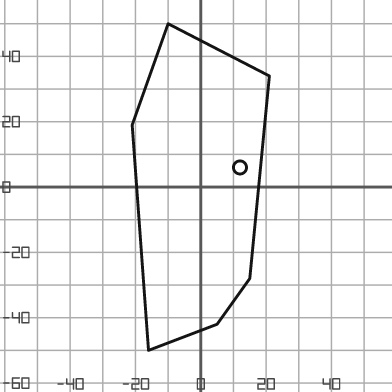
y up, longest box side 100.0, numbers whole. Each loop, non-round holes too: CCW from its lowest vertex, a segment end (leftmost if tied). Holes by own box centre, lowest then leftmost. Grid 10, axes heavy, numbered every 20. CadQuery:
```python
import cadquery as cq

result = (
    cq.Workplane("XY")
    .moveTo(-16.0, -50.0)
    .lineTo(5.0, -42.0)
    .lineTo(15.0, -28.0)
    .lineTo(21.0, 34.0)
    .lineTo(-10.0, 50.0)
    .lineTo(-21.0, 19.0)
    .close()
    .moveTo(12.0, 6.0)
    .circle(2.0)
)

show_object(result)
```